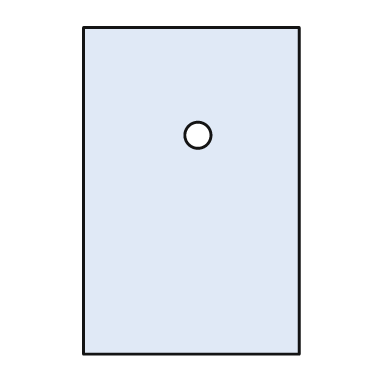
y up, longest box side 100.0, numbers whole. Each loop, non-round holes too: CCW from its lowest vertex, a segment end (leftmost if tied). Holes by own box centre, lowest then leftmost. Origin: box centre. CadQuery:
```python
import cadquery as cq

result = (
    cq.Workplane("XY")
    .moveTo(-33.0, -50.0)
    .lineTo(33.0, -50.0)
    .lineTo(33.0, 50.0)
    .lineTo(-33.0, 50.0)
    .close()
    .moveTo(2.0, 17.0)
    .circle(4.0)
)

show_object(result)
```